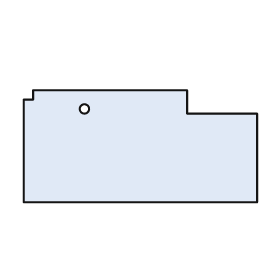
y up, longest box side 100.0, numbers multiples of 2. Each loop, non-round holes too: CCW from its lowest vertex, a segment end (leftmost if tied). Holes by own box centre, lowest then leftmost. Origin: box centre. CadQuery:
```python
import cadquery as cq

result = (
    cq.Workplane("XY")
    .moveTo(-50.0, -24.0)
    .lineTo(50.0, -24.0)
    .lineTo(50.0, 14.0)
    .lineTo(20.0, 14.0)
    .lineTo(20.0, 24.0)
    .lineTo(-46.0, 24.0)
    .lineTo(-46.0, 20.0)
    .lineTo(-50.0, 20.0)
    .close()
    .moveTo(-24.0, 16.0)
    .circle(2.0)
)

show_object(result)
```